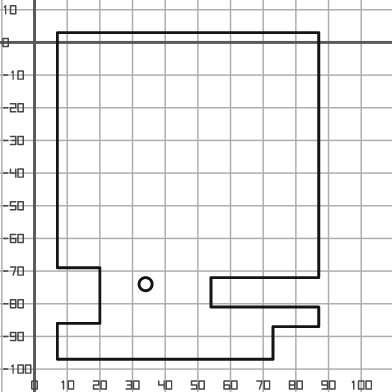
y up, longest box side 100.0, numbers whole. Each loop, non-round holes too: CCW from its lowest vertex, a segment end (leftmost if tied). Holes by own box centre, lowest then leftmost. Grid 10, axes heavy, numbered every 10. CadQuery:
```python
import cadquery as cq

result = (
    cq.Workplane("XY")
    .moveTo(7.0, -97.0)
    .lineTo(73.0, -97.0)
    .lineTo(73.0, -87.0)
    .lineTo(87.0, -87.0)
    .lineTo(87.0, -81.0)
    .lineTo(54.0, -81.0)
    .lineTo(54.0, -72.0)
    .lineTo(87.0, -72.0)
    .lineTo(87.0, 3.0)
    .lineTo(7.0, 3.0)
    .lineTo(7.0, -69.0)
    .lineTo(20.0, -69.0)
    .lineTo(20.0, -86.0)
    .lineTo(7.0, -86.0)
    .close()
    .moveTo(34.0, -74.0)
    .circle(2.0)
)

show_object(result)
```